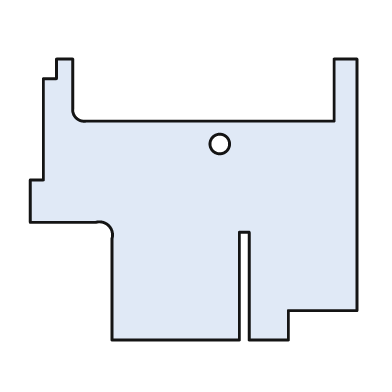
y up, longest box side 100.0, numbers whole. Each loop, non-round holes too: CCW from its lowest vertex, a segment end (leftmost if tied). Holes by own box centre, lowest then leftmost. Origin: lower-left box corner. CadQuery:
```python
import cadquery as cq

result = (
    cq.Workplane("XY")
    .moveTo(25.0, 0.0)
    .lineTo(64.0, 0.0)
    .lineTo(64.0, 33.0)
    .lineTo(67.0, 33.0)
    .lineTo(67.0, 0.0)
    .lineTo(79.0, 0.0)
    .lineTo(79.0, 9.0)
    .lineTo(100.0, 9.0)
    .lineTo(100.0, 86.0)
    .lineTo(93.0, 86.0)
    .lineTo(93.0, 67.0)
    .lineTo(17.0, 67.0)
    .threePointArc((14.0, 68.0), (13.0, 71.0))
    .lineTo(13.0, 86.0)
    .lineTo(8.0, 86.0)
    .lineTo(8.0, 80.0)
    .lineTo(4.0, 80.0)
    .lineTo(4.0, 49.0)
    .lineTo(0.0, 49.0)
    .lineTo(0.0, 36.0)
    .lineTo(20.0, 36.0)
    .threePointArc((24.0, 35.0), (25.0, 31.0))
    .close()
    .moveTo(58.0, 60.0)
    .circle(3.0)
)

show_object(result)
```